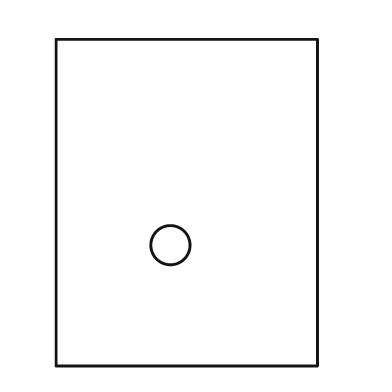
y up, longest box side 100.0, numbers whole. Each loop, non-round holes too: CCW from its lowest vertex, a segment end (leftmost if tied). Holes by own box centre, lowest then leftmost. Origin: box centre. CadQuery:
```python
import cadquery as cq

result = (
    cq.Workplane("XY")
    .moveTo(-40.0, -50.0)
    .lineTo(40.0, -50.0)
    .lineTo(40.0, 50.0)
    .lineTo(-40.0, 50.0)
    .close()
    .moveTo(-5.0, -13.0)
    .circle(6.0)
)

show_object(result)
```